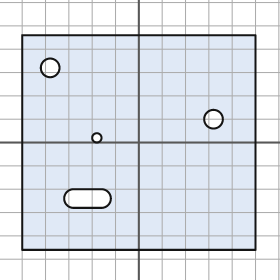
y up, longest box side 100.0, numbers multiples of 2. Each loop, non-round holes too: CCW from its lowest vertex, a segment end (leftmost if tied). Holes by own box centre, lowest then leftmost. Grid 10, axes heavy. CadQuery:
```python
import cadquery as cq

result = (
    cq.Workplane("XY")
    .moveTo(-50.0, -46.0)
    .lineTo(50.0, -46.0)
    .lineTo(50.0, 46.0)
    .lineTo(-50.0, 46.0)
    .close()
    .moveTo(-28.0, -28.0)
    .lineTo(-16.0, -28.0)
    .threePointArc((-12.0, -24.0), (-16.0, -20.0))
    .lineTo(-28.0, -20.0)
    .threePointArc((-32.0, -24.0), (-28.0, -28.0))
    .close()
    .moveTo(-18.0, 2.0)
    .circle(2.0)
    .moveTo(32.0, 10.0)
    .circle(4.0)
    .moveTo(-38.0, 32.0)
    .circle(4.0)
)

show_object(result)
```